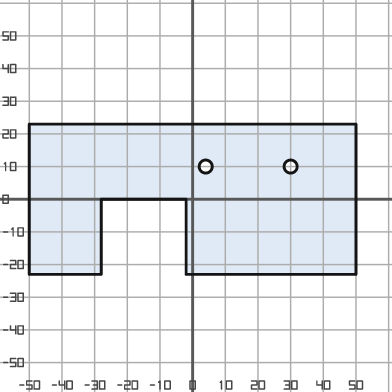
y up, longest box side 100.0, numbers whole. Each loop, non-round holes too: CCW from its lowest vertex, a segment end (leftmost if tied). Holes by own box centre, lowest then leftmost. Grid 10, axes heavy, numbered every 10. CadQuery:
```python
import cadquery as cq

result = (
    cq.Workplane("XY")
    .moveTo(-50.0, -23.0)
    .lineTo(-28.0, -23.0)
    .lineTo(-28.0, 0.0)
    .lineTo(-2.0, 0.0)
    .lineTo(-2.0, -23.0)
    .lineTo(50.0, -23.0)
    .lineTo(50.0, 23.0)
    .lineTo(-50.0, 23.0)
    .close()
    .moveTo(4.0, 10.0)
    .circle(2.0)
    .moveTo(30.0, 10.0)
    .circle(2.0)
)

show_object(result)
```